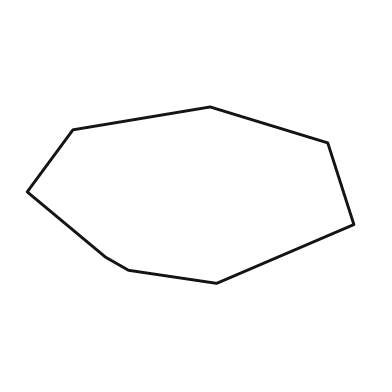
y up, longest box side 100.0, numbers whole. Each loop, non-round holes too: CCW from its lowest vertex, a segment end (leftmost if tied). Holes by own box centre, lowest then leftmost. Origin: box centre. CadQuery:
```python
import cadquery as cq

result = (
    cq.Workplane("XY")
    .moveTo(8.0, -27.0)
    .lineTo(50.0, -9.0)
    .lineTo(42.0, 16.0)
    .lineTo(6.0, 27.0)
    .lineTo(-36.0, 20.0)
    .lineTo(-50.0, 1.0)
    .lineTo(-26.0, -19.0)
    .lineTo(-19.0, -23.0)
    .close()
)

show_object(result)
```